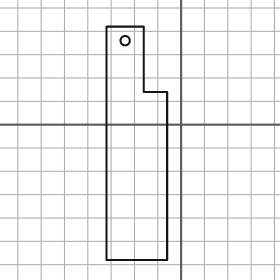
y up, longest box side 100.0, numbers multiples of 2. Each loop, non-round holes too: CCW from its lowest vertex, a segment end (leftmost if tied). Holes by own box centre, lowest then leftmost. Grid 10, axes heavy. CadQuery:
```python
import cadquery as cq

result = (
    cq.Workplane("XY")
    .moveTo(-32.0, -58.0)
    .lineTo(-6.0, -58.0)
    .lineTo(-6.0, 14.0)
    .lineTo(-16.0, 14.0)
    .lineTo(-16.0, 42.0)
    .lineTo(-32.0, 42.0)
    .close()
    .moveTo(-24.0, 36.0)
    .circle(2.0)
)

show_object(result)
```